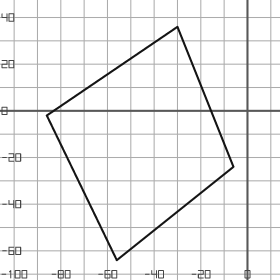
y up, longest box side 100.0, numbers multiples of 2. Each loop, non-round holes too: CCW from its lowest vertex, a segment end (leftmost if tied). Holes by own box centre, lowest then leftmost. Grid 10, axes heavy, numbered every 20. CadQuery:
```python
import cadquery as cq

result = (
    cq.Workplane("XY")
    .moveTo(-56.0, -64.0)
    .lineTo(-6.0, -24.0)
    .lineTo(-30.0, 36.0)
    .lineTo(-86.0, -2.0)
    .close()
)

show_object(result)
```